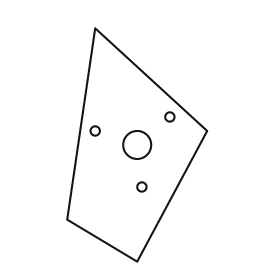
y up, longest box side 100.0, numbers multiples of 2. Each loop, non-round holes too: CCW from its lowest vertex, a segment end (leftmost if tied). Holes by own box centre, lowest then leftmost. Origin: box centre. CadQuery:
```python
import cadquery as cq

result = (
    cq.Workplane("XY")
    .moveTo(0.0, -50.0)
    .lineTo(30.0, 6.0)
    .lineTo(-18.0, 50.0)
    .lineTo(-30.0, -32.0)
    .close()
    .moveTo(2.0, -18.0)
    .circle(2.0)
    .moveTo(0.0, 0.0)
    .circle(6.0)
    .moveTo(-18.0, 6.0)
    .circle(2.0)
    .moveTo(14.0, 12.0)
    .circle(2.0)
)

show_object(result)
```